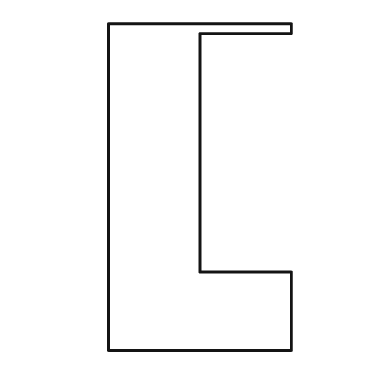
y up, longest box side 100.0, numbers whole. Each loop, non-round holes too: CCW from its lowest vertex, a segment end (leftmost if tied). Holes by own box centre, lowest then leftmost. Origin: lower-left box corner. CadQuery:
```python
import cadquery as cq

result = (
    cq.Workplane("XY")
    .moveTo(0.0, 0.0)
    .lineTo(56.0, 0.0)
    .lineTo(56.0, 24.0)
    .lineTo(28.0, 24.0)
    .lineTo(28.0, 97.0)
    .lineTo(56.0, 97.0)
    .lineTo(56.0, 100.0)
    .lineTo(0.0, 100.0)
    .close()
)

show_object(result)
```